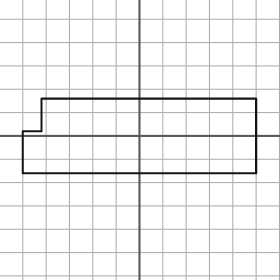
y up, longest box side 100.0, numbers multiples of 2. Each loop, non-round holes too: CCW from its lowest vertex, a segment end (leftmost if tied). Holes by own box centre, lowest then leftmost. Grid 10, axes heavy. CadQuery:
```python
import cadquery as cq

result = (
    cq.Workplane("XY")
    .moveTo(-50.0, -16.0)
    .lineTo(50.0, -16.0)
    .lineTo(50.0, 16.0)
    .lineTo(-42.0, 16.0)
    .lineTo(-42.0, 2.0)
    .lineTo(-50.0, 2.0)
    .close()
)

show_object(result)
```